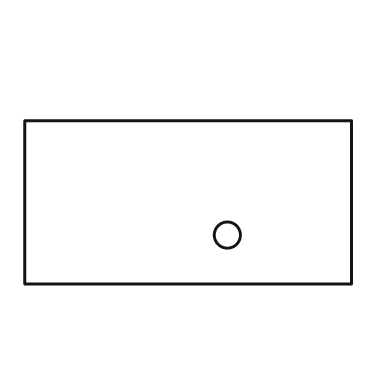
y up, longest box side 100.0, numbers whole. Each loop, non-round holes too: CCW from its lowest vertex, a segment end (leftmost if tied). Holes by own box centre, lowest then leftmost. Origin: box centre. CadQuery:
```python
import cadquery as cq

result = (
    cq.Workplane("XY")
    .moveTo(-50.0, -25.0)
    .lineTo(50.0, -25.0)
    .lineTo(50.0, 25.0)
    .lineTo(-50.0, 25.0)
    .close()
    .moveTo(12.0, -10.0)
    .circle(4.0)
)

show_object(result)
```